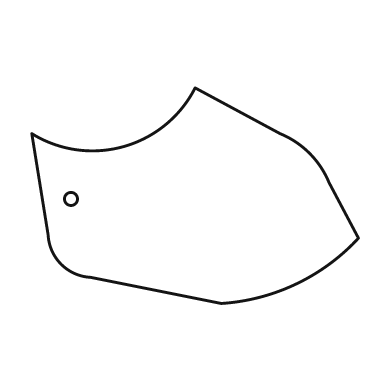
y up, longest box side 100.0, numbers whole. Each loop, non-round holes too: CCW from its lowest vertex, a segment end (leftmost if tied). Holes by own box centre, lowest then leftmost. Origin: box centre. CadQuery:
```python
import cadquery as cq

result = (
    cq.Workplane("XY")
    .moveTo(8.0, -33.0)
    .threePointArc((31.0, -27.0), (50.0, -13.0))
    .lineTo(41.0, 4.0)
    .threePointArc((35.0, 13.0), (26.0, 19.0))
    .lineTo(0.0, 33.0)
    .threePointArc((-22.0, 15.0), (-50.0, 19.0))
    .lineTo(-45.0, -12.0)
    .threePointArc((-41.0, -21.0), (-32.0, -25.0))
    .close()
    .moveTo(-38.0, -1.0)
    .circle(2.0)
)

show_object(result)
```